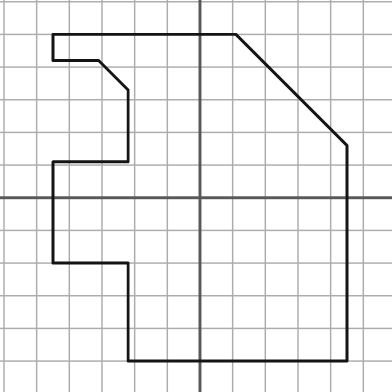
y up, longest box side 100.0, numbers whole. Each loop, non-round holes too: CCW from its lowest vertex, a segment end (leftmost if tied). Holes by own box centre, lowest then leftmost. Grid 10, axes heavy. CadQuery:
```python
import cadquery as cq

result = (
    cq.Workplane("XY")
    .moveTo(-22.0, -50.0)
    .lineTo(45.0, -50.0)
    .lineTo(45.0, 16.0)
    .lineTo(11.0, 50.0)
    .lineTo(-45.0, 50.0)
    .lineTo(-45.0, 42.0)
    .lineTo(-31.0, 42.0)
    .lineTo(-22.0, 33.0)
    .lineTo(-22.0, 11.0)
    .lineTo(-45.0, 11.0)
    .lineTo(-45.0, -20.0)
    .lineTo(-22.0, -20.0)
    .close()
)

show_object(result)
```